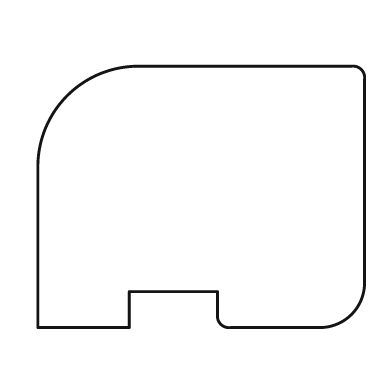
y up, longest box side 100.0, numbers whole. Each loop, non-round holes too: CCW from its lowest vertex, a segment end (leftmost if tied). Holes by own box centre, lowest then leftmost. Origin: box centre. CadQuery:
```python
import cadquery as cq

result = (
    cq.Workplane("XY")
    .moveTo(-50.0, -40.0)
    .lineTo(-22.0, -40.0)
    .lineTo(-22.0, -29.0)
    .lineTo(5.0, -29.0)
    .lineTo(5.0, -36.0)
    .threePointArc((6.0, -39.0), (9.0, -40.0))
    .lineTo(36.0, -40.0)
    .threePointArc((46.0, -36.0), (50.0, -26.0))
    .lineTo(50.0, 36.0)
    .threePointArc((49.0, 39.0), (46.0, 40.0))
    .lineTo(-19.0, 40.0)
    .threePointArc((-41.0, 31.0), (-50.0, 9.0))
    .close()
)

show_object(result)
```